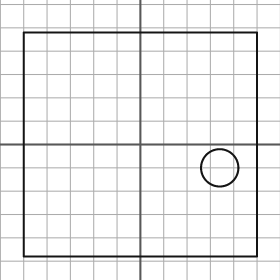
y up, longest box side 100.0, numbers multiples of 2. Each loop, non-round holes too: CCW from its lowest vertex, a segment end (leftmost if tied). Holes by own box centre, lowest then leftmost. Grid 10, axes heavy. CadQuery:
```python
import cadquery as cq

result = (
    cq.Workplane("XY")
    .moveTo(-50.0, -48.0)
    .lineTo(50.0, -48.0)
    .lineTo(50.0, 48.0)
    .lineTo(-50.0, 48.0)
    .close()
    .moveTo(34.0, -10.0)
    .circle(8.0)
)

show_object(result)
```